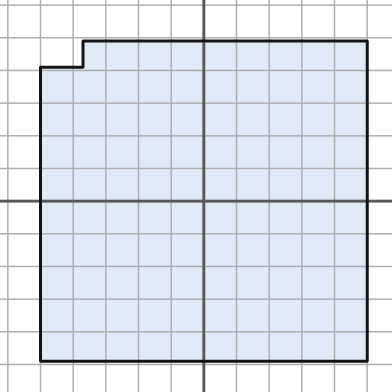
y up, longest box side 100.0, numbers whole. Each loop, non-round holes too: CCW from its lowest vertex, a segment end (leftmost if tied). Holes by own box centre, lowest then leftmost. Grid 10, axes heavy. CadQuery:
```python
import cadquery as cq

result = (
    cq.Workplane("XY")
    .moveTo(-50.0, -49.0)
    .lineTo(50.0, -49.0)
    .lineTo(50.0, 49.0)
    .lineTo(-37.0, 49.0)
    .lineTo(-37.0, 41.0)
    .lineTo(-50.0, 41.0)
    .close()
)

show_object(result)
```